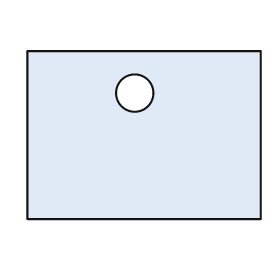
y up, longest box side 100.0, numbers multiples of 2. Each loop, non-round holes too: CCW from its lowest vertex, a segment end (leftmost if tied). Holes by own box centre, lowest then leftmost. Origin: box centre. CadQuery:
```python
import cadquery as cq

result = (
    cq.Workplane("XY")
    .moveTo(-50.0, -36.0)
    .lineTo(50.0, -36.0)
    .lineTo(50.0, 36.0)
    .lineTo(-50.0, 36.0)
    .close()
    .moveTo(-4.0, 18.0)
    .circle(8.0)
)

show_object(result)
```